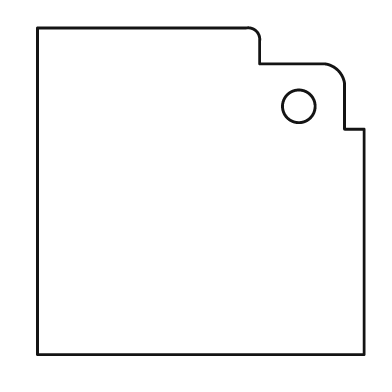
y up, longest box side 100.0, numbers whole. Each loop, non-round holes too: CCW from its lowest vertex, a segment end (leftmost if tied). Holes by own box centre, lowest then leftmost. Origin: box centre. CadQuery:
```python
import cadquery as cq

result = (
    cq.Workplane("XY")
    .moveTo(-50.0, -50.0)
    .lineTo(50.0, -50.0)
    .lineTo(50.0, 19.0)
    .lineTo(44.0, 19.0)
    .lineTo(44.0, 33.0)
    .threePointArc((42.0, 37.0), (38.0, 39.0))
    .lineTo(18.0, 39.0)
    .lineTo(18.0, 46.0)
    .threePointArc((17.0, 49.0), (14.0, 50.0))
    .lineTo(-50.0, 50.0)
    .close()
    .moveTo(30.0, 26.0)
    .circle(5.0)
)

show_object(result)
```